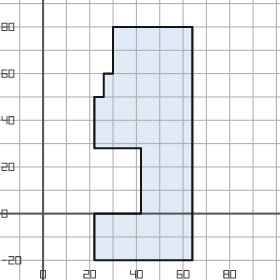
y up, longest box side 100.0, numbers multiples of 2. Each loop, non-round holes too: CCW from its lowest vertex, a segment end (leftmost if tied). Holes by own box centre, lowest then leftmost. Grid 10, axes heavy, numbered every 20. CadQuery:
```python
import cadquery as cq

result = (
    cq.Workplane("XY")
    .moveTo(22.0, -20.0)
    .lineTo(64.0, -20.0)
    .lineTo(64.0, 80.0)
    .lineTo(30.0, 80.0)
    .lineTo(30.0, 60.0)
    .lineTo(26.0, 60.0)
    .lineTo(26.0, 50.0)
    .lineTo(22.0, 50.0)
    .lineTo(22.0, 28.0)
    .lineTo(42.0, 28.0)
    .lineTo(42.0, 0.0)
    .lineTo(22.0, 0.0)
    .close()
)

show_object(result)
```